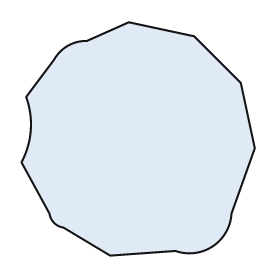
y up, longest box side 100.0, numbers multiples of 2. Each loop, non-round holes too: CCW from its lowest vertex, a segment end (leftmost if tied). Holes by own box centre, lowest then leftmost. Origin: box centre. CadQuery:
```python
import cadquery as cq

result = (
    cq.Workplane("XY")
    .moveTo(-12.0, -50.0)
    .lineTo(16.0, -48.0)
    .threePointArc((32.0, -46.0), (40.0, -32.0))
    .lineTo(50.0, -4.0)
    .lineTo(44.0, 24.0)
    .lineTo(24.0, 44.0)
    .lineTo(-4.0, 50.0)
    .lineTo(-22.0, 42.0)
    .threePointArc((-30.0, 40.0), (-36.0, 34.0))
    .lineTo(-48.0, 18.0)
    .threePointArc((-46.0, 4.0), (-50.0, -10.0))
    .lineTo(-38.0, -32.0)
    .threePointArc((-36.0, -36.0), (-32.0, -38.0))
    .close()
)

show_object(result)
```